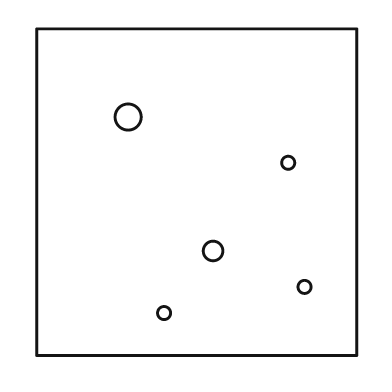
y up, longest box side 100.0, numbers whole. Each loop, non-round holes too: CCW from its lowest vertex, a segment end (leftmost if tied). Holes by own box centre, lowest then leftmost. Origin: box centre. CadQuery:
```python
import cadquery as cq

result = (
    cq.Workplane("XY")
    .moveTo(-49.0, -50.0)
    .lineTo(49.0, -50.0)
    .lineTo(49.0, 50.0)
    .lineTo(-49.0, 50.0)
    .close()
    .moveTo(-10.0, -37.0)
    .circle(2.0)
    .moveTo(33.0, -29.0)
    .circle(2.0)
    .moveTo(5.0, -18.0)
    .circle(3.0)
    .moveTo(28.0, 9.0)
    .circle(2.0)
    .moveTo(-21.0, 23.0)
    .circle(4.0)
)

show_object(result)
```